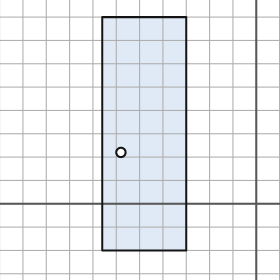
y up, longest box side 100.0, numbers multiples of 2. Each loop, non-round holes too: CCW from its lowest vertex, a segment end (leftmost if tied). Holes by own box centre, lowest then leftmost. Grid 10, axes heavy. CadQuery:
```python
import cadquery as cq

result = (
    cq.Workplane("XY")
    .moveTo(-66.0, -20.0)
    .lineTo(-30.0, -20.0)
    .lineTo(-30.0, 80.0)
    .lineTo(-66.0, 80.0)
    .close()
    .moveTo(-58.0, 22.0)
    .circle(2.0)
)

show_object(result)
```